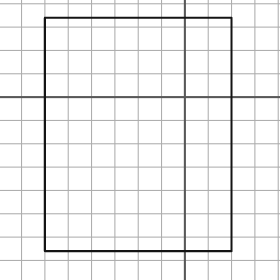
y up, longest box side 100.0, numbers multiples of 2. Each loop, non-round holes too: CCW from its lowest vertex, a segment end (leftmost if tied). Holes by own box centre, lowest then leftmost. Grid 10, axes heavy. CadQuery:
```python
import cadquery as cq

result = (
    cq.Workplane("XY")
    .moveTo(-60.0, -66.0)
    .lineTo(20.0, -66.0)
    .lineTo(20.0, 34.0)
    .lineTo(-60.0, 34.0)
    .close()
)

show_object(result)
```